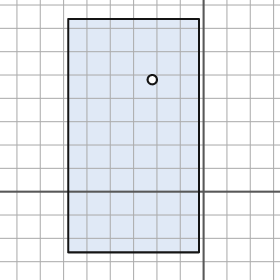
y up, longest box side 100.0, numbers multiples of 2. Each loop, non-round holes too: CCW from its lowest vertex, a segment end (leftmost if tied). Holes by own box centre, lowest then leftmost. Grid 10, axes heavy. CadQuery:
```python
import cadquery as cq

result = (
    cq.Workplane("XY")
    .moveTo(-58.0, -26.0)
    .lineTo(-2.0, -26.0)
    .lineTo(-2.0, 74.0)
    .lineTo(-58.0, 74.0)
    .close()
    .moveTo(-22.0, 48.0)
    .circle(2.0)
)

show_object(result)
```